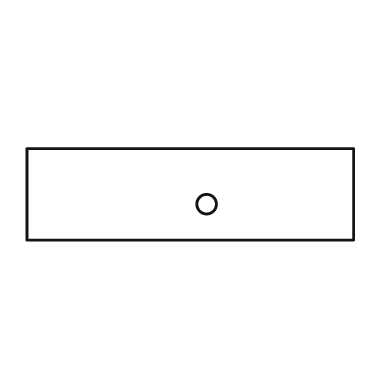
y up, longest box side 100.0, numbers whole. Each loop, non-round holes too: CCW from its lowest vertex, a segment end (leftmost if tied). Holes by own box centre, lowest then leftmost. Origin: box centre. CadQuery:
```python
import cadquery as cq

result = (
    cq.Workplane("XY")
    .moveTo(-50.0, -14.0)
    .lineTo(50.0, -14.0)
    .lineTo(50.0, 14.0)
    .lineTo(-50.0, 14.0)
    .close()
    .moveTo(5.0, -3.0)
    .circle(3.0)
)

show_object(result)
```